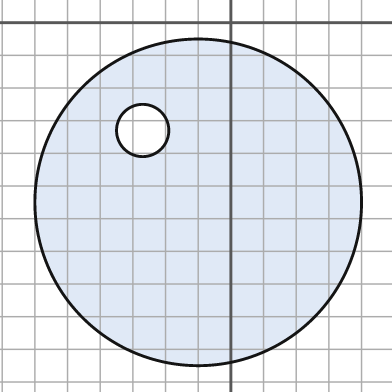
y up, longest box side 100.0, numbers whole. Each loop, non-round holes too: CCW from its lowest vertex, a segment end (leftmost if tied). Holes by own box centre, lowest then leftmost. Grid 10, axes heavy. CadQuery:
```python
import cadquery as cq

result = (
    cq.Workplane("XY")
    .moveTo(-10.0, -55.0)
    .circle(50.0)
    .moveTo(-27.0, -33.0)
    .circle(8.0)
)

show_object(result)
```